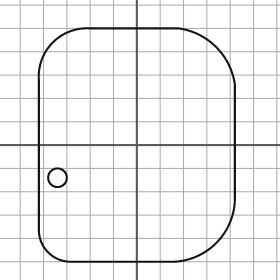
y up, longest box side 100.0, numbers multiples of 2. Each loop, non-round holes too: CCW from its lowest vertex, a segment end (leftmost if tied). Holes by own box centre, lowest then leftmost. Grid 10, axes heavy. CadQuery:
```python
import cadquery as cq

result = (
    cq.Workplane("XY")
    .moveTo(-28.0, -50.0)
    .lineTo(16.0, -50.0)
    .threePointArc((34.0, -42.0), (42.0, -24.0))
    .lineTo(42.0, 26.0)
    .threePointArc((34.0, 42.0), (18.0, 50.0))
    .lineTo(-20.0, 50.0)
    .threePointArc((-36.0, 44.0), (-42.0, 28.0))
    .lineTo(-42.0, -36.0)
    .threePointArc((-38.0, -46.0), (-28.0, -50.0))
    .close()
    .moveTo(-34.0, -14.0)
    .circle(4.0)
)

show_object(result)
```